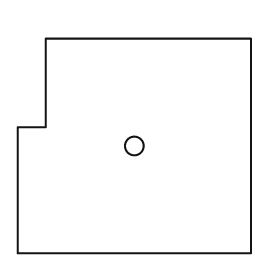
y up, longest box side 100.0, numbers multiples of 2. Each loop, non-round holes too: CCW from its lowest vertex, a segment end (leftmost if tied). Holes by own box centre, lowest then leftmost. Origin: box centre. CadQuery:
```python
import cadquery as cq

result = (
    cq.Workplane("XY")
    .moveTo(-50.0, -46.0)
    .lineTo(50.0, -46.0)
    .lineTo(50.0, 46.0)
    .lineTo(-38.0, 46.0)
    .lineTo(-38.0, 8.0)
    .lineTo(-50.0, 8.0)
    .close()
    .moveTo(0.0, 0.0)
    .circle(4.0)
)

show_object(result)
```